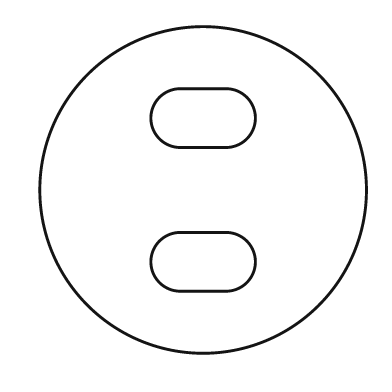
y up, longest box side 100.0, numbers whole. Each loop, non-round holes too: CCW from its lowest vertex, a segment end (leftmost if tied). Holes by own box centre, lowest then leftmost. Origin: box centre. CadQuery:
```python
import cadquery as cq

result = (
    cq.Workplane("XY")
    .moveTo(0.0, 0.0)
    .circle(50.0)
    .moveTo(-7.0, -31.0)
    .lineTo(7.0, -31.0)
    .threePointArc((16.0, -22.0), (7.0, -13.0))
    .lineTo(-7.0, -13.0)
    .threePointArc((-16.0, -22.0), (-7.0, -31.0))
    .close()
    .moveTo(-7.0, 13.0)
    .lineTo(7.0, 13.0)
    .threePointArc((16.0, 22.0), (7.0, 31.0))
    .lineTo(-7.0, 31.0)
    .threePointArc((-16.0, 22.0), (-7.0, 13.0))
    .close()
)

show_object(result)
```